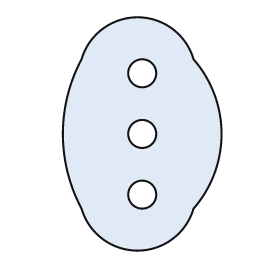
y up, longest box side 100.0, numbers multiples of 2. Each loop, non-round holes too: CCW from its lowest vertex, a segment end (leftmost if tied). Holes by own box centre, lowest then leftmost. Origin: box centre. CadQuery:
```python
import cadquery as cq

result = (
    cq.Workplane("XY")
    .moveTo(-26.0, -32.0)
    .threePointArc((-2.0, -50.0), (22.0, -32.0))
    .threePointArc((34.0, 0.0), (22.0, 32.0))
    .threePointArc((-2.0, 50.0), (-26.0, 32.0))
    .threePointArc((-34.0, 0.0), (-26.0, -32.0))
    .close()
    .moveTo(0.0, -26.0)
    .circle(6.0)
    .moveTo(0.0, 0.0)
    .circle(6.0)
    .moveTo(0.0, 26.0)
    .circle(6.0)
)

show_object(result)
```